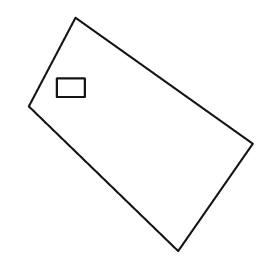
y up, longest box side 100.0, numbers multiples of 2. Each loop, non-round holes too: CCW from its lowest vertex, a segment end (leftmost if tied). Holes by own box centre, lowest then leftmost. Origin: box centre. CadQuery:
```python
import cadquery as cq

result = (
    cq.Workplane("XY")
    .moveTo(16.0, -50.0)
    .lineTo(48.0, -4.0)
    .lineTo(-28.0, 50.0)
    .lineTo(-48.0, 12.0)
    .close()
    .moveTo(-36.0, 16.0)
    .lineTo(-24.0, 16.0)
    .lineTo(-24.0, 24.0)
    .lineTo(-36.0, 24.0)
    .close()
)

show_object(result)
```